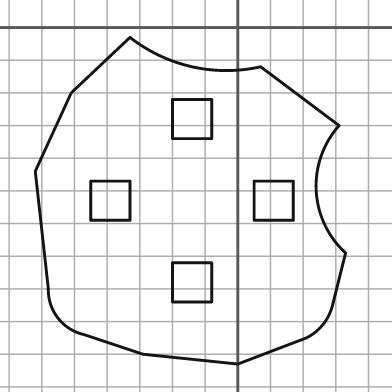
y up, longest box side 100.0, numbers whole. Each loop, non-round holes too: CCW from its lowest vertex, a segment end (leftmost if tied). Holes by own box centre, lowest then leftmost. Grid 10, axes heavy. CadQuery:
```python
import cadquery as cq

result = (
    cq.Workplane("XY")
    .moveTo(0.0, -103.0)
    .lineTo(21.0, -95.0)
    .threePointArc((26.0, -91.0), (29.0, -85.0))
    .lineTo(33.0, -69.0)
    .threePointArc((24.0, -50.0), (31.0, -30.0))
    .lineTo(7.0, -12.0)
    .threePointArc((-14.0, -12.0), (-33.0, -3.0))
    .lineTo(-51.0, -20.0)
    .lineTo(-62.0, -44.0)
    .lineTo(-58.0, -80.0)
    .threePointArc((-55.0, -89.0), (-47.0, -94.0))
    .lineTo(-29.0, -100.0)
    .close()
    .moveTo(-20.0, -84.0)
    .lineTo(-8.0, -84.0)
    .lineTo(-8.0, -72.0)
    .lineTo(-20.0, -72.0)
    .close()
    .moveTo(-45.0, -59.0)
    .lineTo(-33.0, -59.0)
    .lineTo(-33.0, -47.0)
    .lineTo(-45.0, -47.0)
    .close()
    .moveTo(5.0, -59.0)
    .lineTo(17.0, -59.0)
    .lineTo(17.0, -47.0)
    .lineTo(5.0, -47.0)
    .close()
    .moveTo(-20.0, -34.0)
    .lineTo(-8.0, -34.0)
    .lineTo(-8.0, -22.0)
    .lineTo(-20.0, -22.0)
    .close()
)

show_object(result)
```